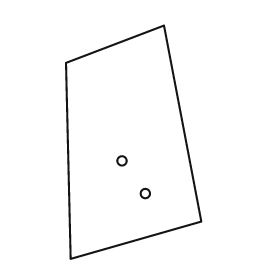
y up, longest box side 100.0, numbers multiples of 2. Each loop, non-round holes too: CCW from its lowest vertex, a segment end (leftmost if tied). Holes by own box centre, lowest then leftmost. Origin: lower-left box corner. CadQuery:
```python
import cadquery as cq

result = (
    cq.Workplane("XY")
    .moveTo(2.0, 0.0)
    .lineTo(58.0, 16.0)
    .lineTo(42.0, 100.0)
    .lineTo(0.0, 84.0)
    .close()
    .moveTo(34.0, 28.0)
    .circle(2.0)
    .moveTo(24.0, 42.0)
    .circle(2.0)
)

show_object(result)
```